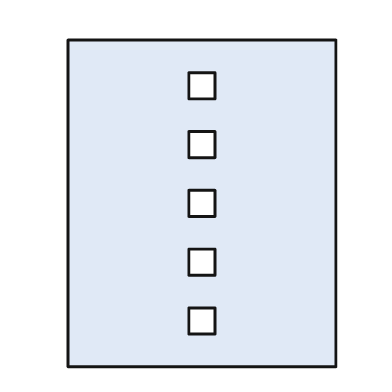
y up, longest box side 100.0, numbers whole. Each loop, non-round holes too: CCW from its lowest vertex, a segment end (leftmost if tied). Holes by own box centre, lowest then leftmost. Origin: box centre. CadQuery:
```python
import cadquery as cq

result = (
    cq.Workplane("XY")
    .moveTo(-41.0, -50.0)
    .lineTo(41.0, -50.0)
    .lineTo(41.0, 50.0)
    .lineTo(-41.0, 50.0)
    .close()
    .moveTo(-4.0, -40.0)
    .lineTo(4.0, -40.0)
    .lineTo(4.0, -32.0)
    .lineTo(-4.0, -32.0)
    .close()
    .moveTo(-4.0, -22.0)
    .lineTo(4.0, -22.0)
    .lineTo(4.0, -14.0)
    .lineTo(-4.0, -14.0)
    .close()
    .moveTo(-4.0, -4.0)
    .lineTo(4.0, -4.0)
    .lineTo(4.0, 4.0)
    .lineTo(-4.0, 4.0)
    .close()
    .moveTo(-4.0, 14.0)
    .lineTo(4.0, 14.0)
    .lineTo(4.0, 22.0)
    .lineTo(-4.0, 22.0)
    .close()
    .moveTo(-4.0, 32.0)
    .lineTo(4.0, 32.0)
    .lineTo(4.0, 40.0)
    .lineTo(-4.0, 40.0)
    .close()
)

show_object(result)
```